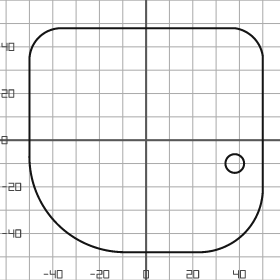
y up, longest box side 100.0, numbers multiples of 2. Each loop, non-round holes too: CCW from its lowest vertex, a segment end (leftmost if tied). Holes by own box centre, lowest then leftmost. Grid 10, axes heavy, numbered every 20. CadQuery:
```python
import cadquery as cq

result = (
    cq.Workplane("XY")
    .moveTo(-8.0, -48.0)
    .lineTo(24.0, -48.0)
    .threePointArc((42.0, -40.0), (50.0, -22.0))
    .lineTo(50.0, 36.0)
    .threePointArc((46.0, 44.0), (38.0, 48.0))
    .lineTo(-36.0, 48.0)
    .threePointArc((-46.0, 44.0), (-50.0, 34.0))
    .lineTo(-50.0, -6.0)
    .threePointArc((-38.0, -36.0), (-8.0, -48.0))
    .close()
    .moveTo(38.0, -10.0)
    .circle(4.0)
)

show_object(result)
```